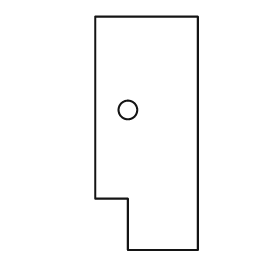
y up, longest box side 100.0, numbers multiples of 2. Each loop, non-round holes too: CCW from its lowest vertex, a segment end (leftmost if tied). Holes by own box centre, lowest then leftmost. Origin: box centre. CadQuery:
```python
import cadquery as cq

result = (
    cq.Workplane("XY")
    .moveTo(-8.0, -50.0)
    .lineTo(22.0, -50.0)
    .lineTo(22.0, 50.0)
    .lineTo(-22.0, 50.0)
    .lineTo(-22.0, -28.0)
    .lineTo(-8.0, -28.0)
    .close()
    .moveTo(-8.0, 10.0)
    .circle(4.0)
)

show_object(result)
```